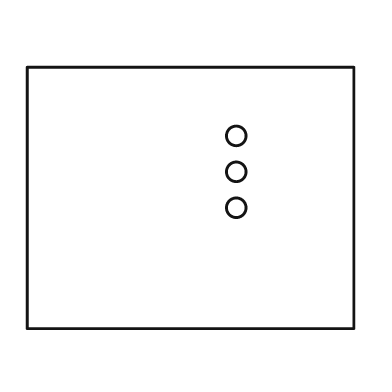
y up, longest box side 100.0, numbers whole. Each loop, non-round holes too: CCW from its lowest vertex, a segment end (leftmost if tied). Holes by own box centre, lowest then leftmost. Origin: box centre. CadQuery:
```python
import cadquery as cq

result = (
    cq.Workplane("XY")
    .moveTo(-50.0, -40.0)
    .lineTo(50.0, -40.0)
    .lineTo(50.0, 40.0)
    .lineTo(-50.0, 40.0)
    .close()
    .moveTo(14.0, -3.0)
    .circle(3.0)
    .moveTo(14.0, 8.0)
    .circle(3.0)
    .moveTo(14.0, 19.0)
    .circle(3.0)
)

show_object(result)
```